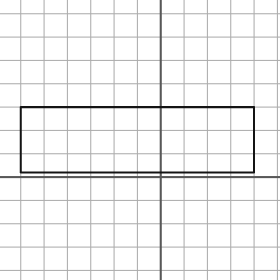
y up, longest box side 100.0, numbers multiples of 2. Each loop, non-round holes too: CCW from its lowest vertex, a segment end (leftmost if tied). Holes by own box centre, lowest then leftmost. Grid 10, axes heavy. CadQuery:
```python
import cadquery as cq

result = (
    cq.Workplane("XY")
    .moveTo(-60.0, 2.0)
    .lineTo(40.0, 2.0)
    .lineTo(40.0, 30.0)
    .lineTo(-60.0, 30.0)
    .close()
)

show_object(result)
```